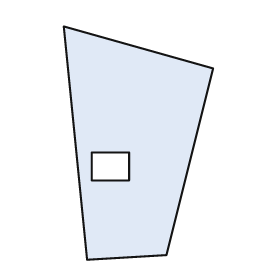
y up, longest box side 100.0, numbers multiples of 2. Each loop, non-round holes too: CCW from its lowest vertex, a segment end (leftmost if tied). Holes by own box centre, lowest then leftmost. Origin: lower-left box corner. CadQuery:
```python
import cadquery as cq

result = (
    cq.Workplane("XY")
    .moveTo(10.0, 0.0)
    .lineTo(44.0, 2.0)
    .lineTo(64.0, 82.0)
    .lineTo(0.0, 100.0)
    .close()
    .moveTo(12.0, 34.0)
    .lineTo(28.0, 34.0)
    .lineTo(28.0, 46.0)
    .lineTo(12.0, 46.0)
    .close()
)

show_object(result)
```